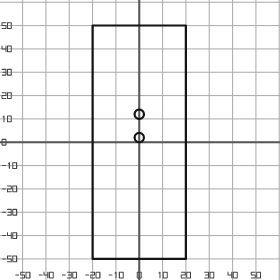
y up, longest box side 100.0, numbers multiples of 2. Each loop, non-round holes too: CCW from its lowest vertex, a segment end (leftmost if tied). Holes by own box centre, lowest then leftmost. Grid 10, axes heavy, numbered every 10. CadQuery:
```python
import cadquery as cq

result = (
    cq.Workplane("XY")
    .moveTo(-20.0, -50.0)
    .lineTo(20.0, -50.0)
    .lineTo(20.0, 50.0)
    .lineTo(-20.0, 50.0)
    .close()
    .moveTo(0.0, 2.0)
    .circle(2.0)
    .moveTo(0.0, 12.0)
    .circle(2.0)
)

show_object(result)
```